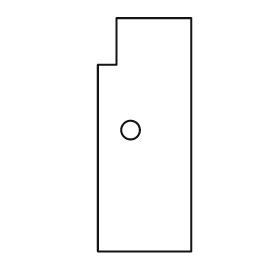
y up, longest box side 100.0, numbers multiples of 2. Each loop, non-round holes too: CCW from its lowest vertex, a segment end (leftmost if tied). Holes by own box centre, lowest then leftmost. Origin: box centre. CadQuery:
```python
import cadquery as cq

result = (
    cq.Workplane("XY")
    .moveTo(-20.0, -50.0)
    .lineTo(20.0, -50.0)
    .lineTo(20.0, 50.0)
    .lineTo(-12.0, 50.0)
    .lineTo(-12.0, 30.0)
    .lineTo(-20.0, 30.0)
    .close()
    .moveTo(-6.0, 2.0)
    .circle(4.0)
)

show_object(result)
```